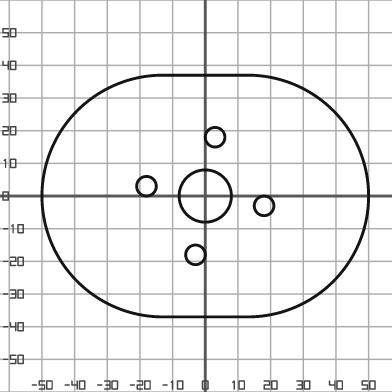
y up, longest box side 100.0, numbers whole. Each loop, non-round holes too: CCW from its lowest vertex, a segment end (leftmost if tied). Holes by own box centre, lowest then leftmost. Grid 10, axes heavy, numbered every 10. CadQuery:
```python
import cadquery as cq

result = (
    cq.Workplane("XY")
    .moveTo(-13.0, -37.0)
    .lineTo(13.0, -37.0)
    .threePointArc((50.0, 0.0), (13.0, 37.0))
    .lineTo(-13.0, 37.0)
    .threePointArc((-50.0, 0.0), (-13.0, -37.0))
    .close()
    .moveTo(-3.0, -18.0)
    .circle(3.0)
    .moveTo(18.0, -3.0)
    .circle(3.0)
    .moveTo(0.0, 0.0)
    .circle(8.0)
    .moveTo(-18.0, 3.0)
    .circle(3.0)
    .moveTo(3.0, 18.0)
    .circle(3.0)
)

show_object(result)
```